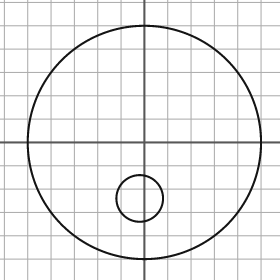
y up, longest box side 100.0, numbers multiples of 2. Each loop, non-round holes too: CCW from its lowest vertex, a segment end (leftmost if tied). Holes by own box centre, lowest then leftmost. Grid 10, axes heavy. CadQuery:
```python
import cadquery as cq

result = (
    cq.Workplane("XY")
    .moveTo(0.0, 0.0)
    .circle(50.0)
    .moveTo(-2.0, -24.0)
    .circle(10.0)
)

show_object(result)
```